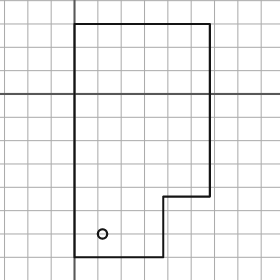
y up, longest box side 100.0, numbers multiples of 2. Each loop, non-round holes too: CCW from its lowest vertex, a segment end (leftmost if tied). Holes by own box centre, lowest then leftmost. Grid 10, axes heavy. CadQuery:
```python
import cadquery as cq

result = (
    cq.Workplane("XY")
    .moveTo(0.0, -70.0)
    .lineTo(38.0, -70.0)
    .lineTo(38.0, -44.0)
    .lineTo(58.0, -44.0)
    .lineTo(58.0, 30.0)
    .lineTo(0.0, 30.0)
    .close()
    .moveTo(12.0, -60.0)
    .circle(2.0)
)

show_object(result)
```